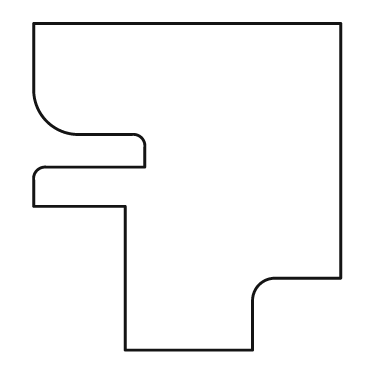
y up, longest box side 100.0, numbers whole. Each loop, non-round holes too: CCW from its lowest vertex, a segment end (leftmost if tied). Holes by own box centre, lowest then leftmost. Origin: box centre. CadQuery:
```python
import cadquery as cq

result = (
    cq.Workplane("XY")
    .moveTo(-19.0, -50.0)
    .lineTo(20.0, -50.0)
    .lineTo(20.0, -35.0)
    .threePointArc((22.0, -30.0), (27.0, -28.0))
    .lineTo(47.0, -28.0)
    .lineTo(47.0, 50.0)
    .lineTo(-47.0, 50.0)
    .lineTo(-47.0, 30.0)
    .threePointArc((-43.0, 20.0), (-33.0, 16.0))
    .lineTo(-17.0, 16.0)
    .threePointArc((-14.0, 15.0), (-13.0, 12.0))
    .lineTo(-13.0, 6.0)
    .lineTo(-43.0, 6.0)
    .threePointArc((-46.0, 5.0), (-47.0, 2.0))
    .lineTo(-47.0, -6.0)
    .lineTo(-19.0, -6.0)
    .close()
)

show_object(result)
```